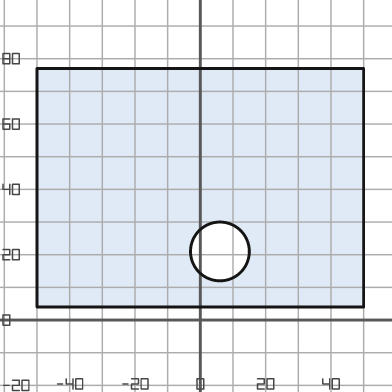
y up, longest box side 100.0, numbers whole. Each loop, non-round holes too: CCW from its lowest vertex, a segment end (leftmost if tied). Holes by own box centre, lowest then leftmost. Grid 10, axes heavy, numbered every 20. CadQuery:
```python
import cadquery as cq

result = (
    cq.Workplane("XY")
    .moveTo(-50.0, 4.0)
    .lineTo(50.0, 4.0)
    .lineTo(50.0, 77.0)
    .lineTo(-50.0, 77.0)
    .close()
    .moveTo(6.0, 21.0)
    .circle(9.0)
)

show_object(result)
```